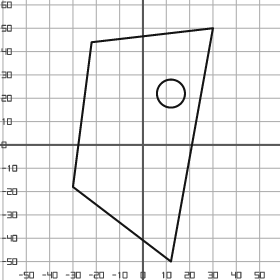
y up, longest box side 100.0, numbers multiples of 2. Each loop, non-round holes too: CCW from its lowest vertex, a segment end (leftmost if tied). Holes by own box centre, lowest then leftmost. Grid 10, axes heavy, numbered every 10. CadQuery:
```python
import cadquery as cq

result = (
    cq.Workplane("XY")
    .moveTo(12.0, -50.0)
    .lineTo(30.0, 50.0)
    .lineTo(-22.0, 44.0)
    .lineTo(-30.0, -18.0)
    .close()
    .moveTo(12.0, 22.0)
    .circle(6.0)
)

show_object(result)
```